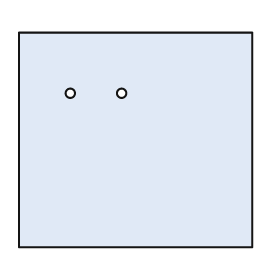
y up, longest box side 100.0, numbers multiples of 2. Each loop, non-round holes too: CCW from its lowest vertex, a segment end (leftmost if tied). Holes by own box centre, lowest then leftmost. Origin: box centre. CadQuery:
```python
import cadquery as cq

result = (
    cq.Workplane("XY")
    .moveTo(-50.0, -46.0)
    .lineTo(50.0, -46.0)
    .lineTo(50.0, 46.0)
    .lineTo(-50.0, 46.0)
    .close()
    .moveTo(-28.0, 20.0)
    .circle(2.0)
    .moveTo(-6.0, 20.0)
    .circle(2.0)
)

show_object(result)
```